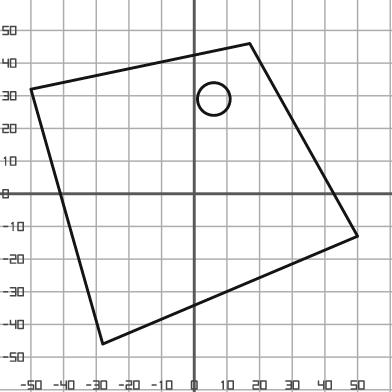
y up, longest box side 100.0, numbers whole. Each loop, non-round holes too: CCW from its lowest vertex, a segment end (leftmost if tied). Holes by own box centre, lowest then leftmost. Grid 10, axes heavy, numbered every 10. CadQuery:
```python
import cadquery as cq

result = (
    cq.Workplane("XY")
    .moveTo(-28.0, -46.0)
    .lineTo(50.0, -13.0)
    .lineTo(17.0, 46.0)
    .lineTo(-50.0, 32.0)
    .close()
    .moveTo(6.0, 29.0)
    .circle(5.0)
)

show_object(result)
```